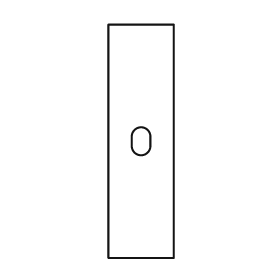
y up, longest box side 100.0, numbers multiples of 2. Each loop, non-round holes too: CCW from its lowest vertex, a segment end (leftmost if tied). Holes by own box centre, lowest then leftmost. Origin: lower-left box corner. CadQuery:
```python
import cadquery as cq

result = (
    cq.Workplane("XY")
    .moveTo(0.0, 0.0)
    .lineTo(28.0, 0.0)
    .lineTo(28.0, 100.0)
    .lineTo(0.0, 100.0)
    .close()
    .moveTo(10.0, 48.0)
    .threePointArc((14.0, 44.0), (18.0, 48.0))
    .lineTo(18.0, 52.0)
    .threePointArc((14.0, 56.0), (10.0, 52.0))
    .close()
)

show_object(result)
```